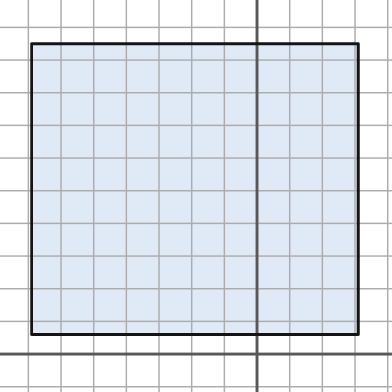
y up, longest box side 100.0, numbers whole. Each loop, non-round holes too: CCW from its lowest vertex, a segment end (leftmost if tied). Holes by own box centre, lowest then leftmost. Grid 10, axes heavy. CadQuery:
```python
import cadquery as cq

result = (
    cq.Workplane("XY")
    .moveTo(-69.0, 6.0)
    .lineTo(31.0, 6.0)
    .lineTo(31.0, 95.0)
    .lineTo(-69.0, 95.0)
    .close()
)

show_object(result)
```